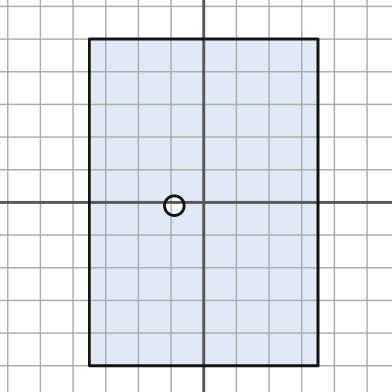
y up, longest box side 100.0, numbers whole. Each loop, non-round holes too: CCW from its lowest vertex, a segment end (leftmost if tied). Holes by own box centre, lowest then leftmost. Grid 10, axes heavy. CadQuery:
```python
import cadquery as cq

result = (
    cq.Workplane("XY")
    .moveTo(-35.0, -50.0)
    .lineTo(35.0, -50.0)
    .lineTo(35.0, 50.0)
    .lineTo(-35.0, 50.0)
    .close()
    .moveTo(-9.0, -1.0)
    .circle(3.0)
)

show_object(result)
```